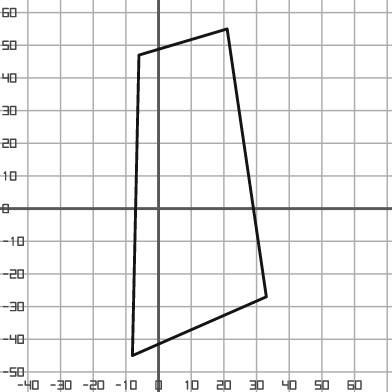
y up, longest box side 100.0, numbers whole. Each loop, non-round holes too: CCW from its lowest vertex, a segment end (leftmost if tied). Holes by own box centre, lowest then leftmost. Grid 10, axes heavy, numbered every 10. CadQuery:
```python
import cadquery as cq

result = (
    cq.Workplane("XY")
    .moveTo(-8.0, -45.0)
    .lineTo(33.0, -27.0)
    .lineTo(21.0, 55.0)
    .lineTo(-6.0, 47.0)
    .close()
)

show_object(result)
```